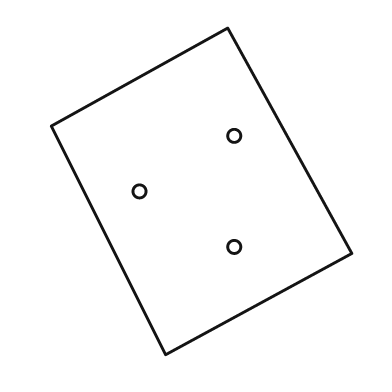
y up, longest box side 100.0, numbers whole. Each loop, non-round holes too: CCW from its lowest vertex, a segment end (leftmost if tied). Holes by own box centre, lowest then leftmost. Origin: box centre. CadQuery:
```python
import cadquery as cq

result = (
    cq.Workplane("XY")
    .moveTo(-11.0, -50.0)
    .lineTo(46.0, -19.0)
    .lineTo(8.0, 50.0)
    .lineTo(-46.0, 20.0)
    .close()
    .moveTo(10.0, -17.0)
    .circle(2.0)
    .moveTo(-19.0, 0.0)
    .circle(2.0)
    .moveTo(10.0, 17.0)
    .circle(2.0)
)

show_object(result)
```